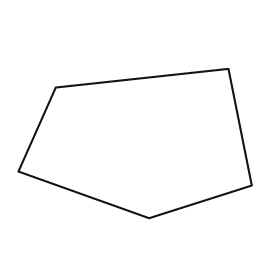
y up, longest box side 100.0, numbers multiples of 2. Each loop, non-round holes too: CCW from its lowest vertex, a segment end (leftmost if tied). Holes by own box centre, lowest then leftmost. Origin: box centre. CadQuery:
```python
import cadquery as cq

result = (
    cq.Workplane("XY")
    .moveTo(6.0, -32.0)
    .lineTo(50.0, -18.0)
    .lineTo(40.0, 32.0)
    .lineTo(-34.0, 24.0)
    .lineTo(-50.0, -12.0)
    .close()
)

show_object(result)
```